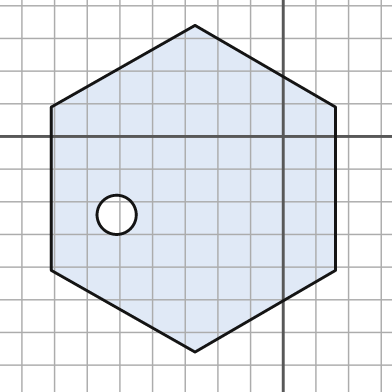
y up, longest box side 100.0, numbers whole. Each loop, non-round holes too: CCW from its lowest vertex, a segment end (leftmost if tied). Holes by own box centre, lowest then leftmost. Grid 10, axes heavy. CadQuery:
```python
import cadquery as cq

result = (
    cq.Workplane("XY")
    .moveTo(-27.0, -66.0)
    .lineTo(16.0, -41.0)
    .lineTo(16.0, 9.0)
    .lineTo(-27.0, 34.0)
    .lineTo(-71.0, 9.0)
    .lineTo(-71.0, -41.0)
    .close()
    .moveTo(-51.0, -24.0)
    .circle(6.0)
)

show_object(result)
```